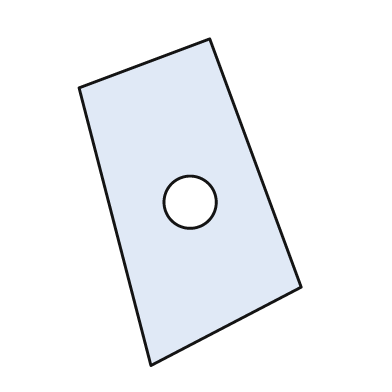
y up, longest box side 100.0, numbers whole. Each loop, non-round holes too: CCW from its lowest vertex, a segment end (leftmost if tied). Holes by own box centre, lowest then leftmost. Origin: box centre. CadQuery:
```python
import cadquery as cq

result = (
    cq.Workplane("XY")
    .moveTo(-12.0, -50.0)
    .lineTo(34.0, -26.0)
    .lineTo(6.0, 50.0)
    .lineTo(-34.0, 35.0)
    .close()
    .moveTo(0.0, 0.0)
    .circle(8.0)
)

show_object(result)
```